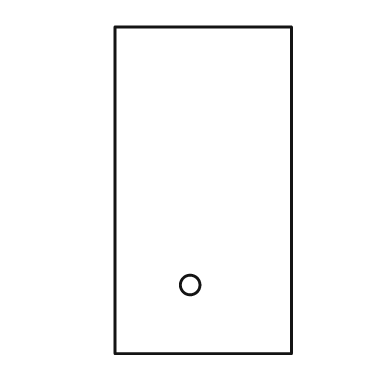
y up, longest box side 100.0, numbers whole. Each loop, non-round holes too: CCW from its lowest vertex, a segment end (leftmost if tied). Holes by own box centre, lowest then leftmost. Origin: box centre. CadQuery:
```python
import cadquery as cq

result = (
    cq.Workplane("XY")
    .moveTo(-27.0, -50.0)
    .lineTo(27.0, -50.0)
    .lineTo(27.0, 50.0)
    .lineTo(-27.0, 50.0)
    .close()
    .moveTo(-4.0, -29.0)
    .circle(3.0)
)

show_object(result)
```